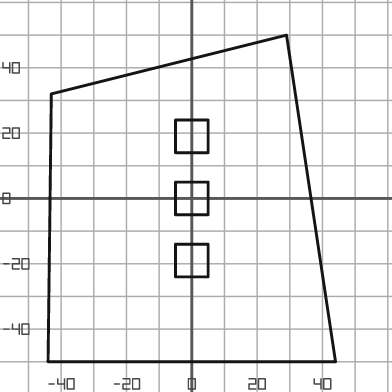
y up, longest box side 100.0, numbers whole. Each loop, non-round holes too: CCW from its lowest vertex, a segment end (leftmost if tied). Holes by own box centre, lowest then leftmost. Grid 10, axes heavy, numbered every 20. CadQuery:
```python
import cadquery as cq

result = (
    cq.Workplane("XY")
    .moveTo(-44.0, -50.0)
    .lineTo(44.0, -50.0)
    .lineTo(29.0, 50.0)
    .lineTo(-43.0, 32.0)
    .close()
    .moveTo(-5.0, -24.0)
    .lineTo(5.0, -24.0)
    .lineTo(5.0, -14.0)
    .lineTo(-5.0, -14.0)
    .close()
    .moveTo(-5.0, -5.0)
    .lineTo(5.0, -5.0)
    .lineTo(5.0, 5.0)
    .lineTo(-5.0, 5.0)
    .close()
    .moveTo(-5.0, 14.0)
    .lineTo(5.0, 14.0)
    .lineTo(5.0, 24.0)
    .lineTo(-5.0, 24.0)
    .close()
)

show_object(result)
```